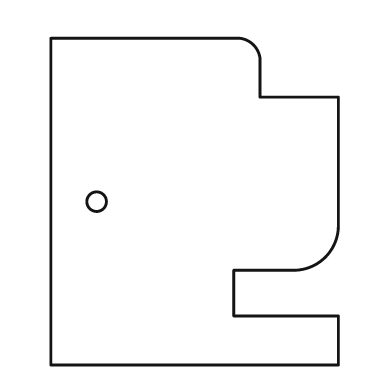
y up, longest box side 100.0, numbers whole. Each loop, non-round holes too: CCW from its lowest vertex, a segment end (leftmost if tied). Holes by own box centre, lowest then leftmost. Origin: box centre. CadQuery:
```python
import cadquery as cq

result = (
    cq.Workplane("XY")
    .moveTo(-44.0, -50.0)
    .lineTo(44.0, -50.0)
    .lineTo(44.0, -35.0)
    .lineTo(12.0, -35.0)
    .lineTo(12.0, -21.0)
    .lineTo(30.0, -21.0)
    .threePointArc((40.0, -17.0), (44.0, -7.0))
    .lineTo(44.0, 32.0)
    .lineTo(20.0, 32.0)
    .lineTo(20.0, 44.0)
    .threePointArc((18.0, 48.0), (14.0, 50.0))
    .lineTo(-44.0, 50.0)
    .close()
    .moveTo(-30.0, 0.0)
    .circle(3.0)
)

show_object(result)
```